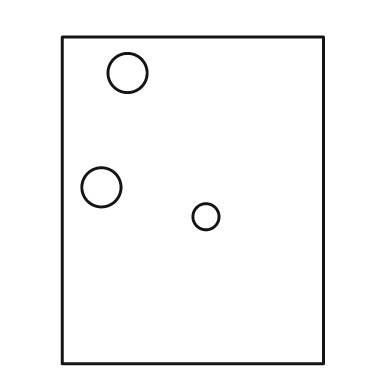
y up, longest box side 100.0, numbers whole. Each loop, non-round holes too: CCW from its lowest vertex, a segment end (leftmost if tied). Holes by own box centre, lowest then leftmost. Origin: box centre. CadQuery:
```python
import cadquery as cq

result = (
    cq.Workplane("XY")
    .moveTo(-40.0, -50.0)
    .lineTo(40.0, -50.0)
    .lineTo(40.0, 50.0)
    .lineTo(-40.0, 50.0)
    .close()
    .moveTo(4.0, -5.0)
    .circle(4.0)
    .moveTo(-28.0, 4.0)
    .circle(6.0)
    .moveTo(-20.0, 39.0)
    .circle(6.0)
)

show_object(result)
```